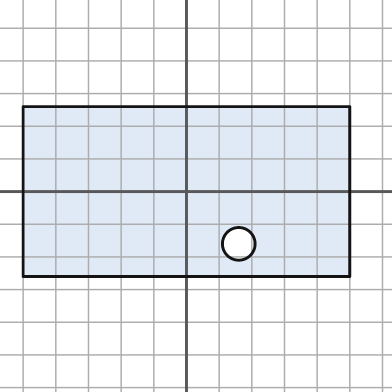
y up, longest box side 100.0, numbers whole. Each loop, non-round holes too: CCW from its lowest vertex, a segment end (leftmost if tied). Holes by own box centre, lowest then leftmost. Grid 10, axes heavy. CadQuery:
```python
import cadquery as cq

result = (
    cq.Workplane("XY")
    .moveTo(-50.0, -26.0)
    .lineTo(50.0, -26.0)
    .lineTo(50.0, 26.0)
    .lineTo(-50.0, 26.0)
    .close()
    .moveTo(16.0, -16.0)
    .circle(5.0)
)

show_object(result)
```